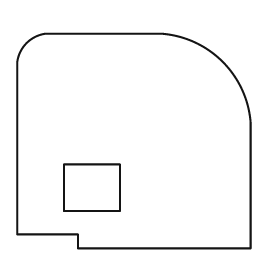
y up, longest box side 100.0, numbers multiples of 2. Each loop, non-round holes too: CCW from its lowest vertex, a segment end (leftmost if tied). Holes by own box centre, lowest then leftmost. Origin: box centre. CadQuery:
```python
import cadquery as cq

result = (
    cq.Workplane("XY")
    .moveTo(-24.0, -46.0)
    .lineTo(50.0, -46.0)
    .lineTo(50.0, 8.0)
    .threePointArc((38.0, 34.0), (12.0, 46.0))
    .lineTo(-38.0, 46.0)
    .threePointArc((-46.0, 42.0), (-50.0, 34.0))
    .lineTo(-50.0, -40.0)
    .lineTo(-24.0, -40.0)
    .close()
    .moveTo(-30.0, -30.0)
    .lineTo(-6.0, -30.0)
    .lineTo(-6.0, -10.0)
    .lineTo(-30.0, -10.0)
    .close()
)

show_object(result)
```